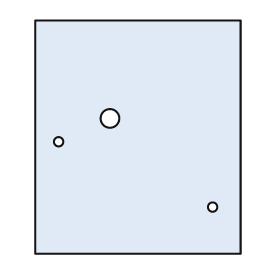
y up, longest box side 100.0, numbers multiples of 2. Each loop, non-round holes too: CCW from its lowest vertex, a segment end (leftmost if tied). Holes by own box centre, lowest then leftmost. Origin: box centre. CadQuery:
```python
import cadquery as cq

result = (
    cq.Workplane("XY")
    .moveTo(-44.0, -50.0)
    .lineTo(44.0, -50.0)
    .lineTo(44.0, 50.0)
    .lineTo(-44.0, 50.0)
    .close()
    .moveTo(32.0, -30.0)
    .circle(2.0)
    .moveTo(-34.0, -2.0)
    .circle(2.0)
    .moveTo(-12.0, 8.0)
    .circle(4.0)
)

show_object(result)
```